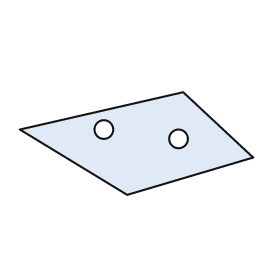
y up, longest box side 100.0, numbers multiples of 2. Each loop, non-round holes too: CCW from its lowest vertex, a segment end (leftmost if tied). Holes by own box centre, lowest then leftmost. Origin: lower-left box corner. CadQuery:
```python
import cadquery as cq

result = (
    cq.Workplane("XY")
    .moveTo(46.0, 0.0)
    .lineTo(100.0, 16.0)
    .lineTo(70.0, 44.0)
    .lineTo(0.0, 28.0)
    .close()
    .moveTo(68.0, 24.0)
    .circle(4.0)
    .moveTo(36.0, 28.0)
    .circle(4.0)
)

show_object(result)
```